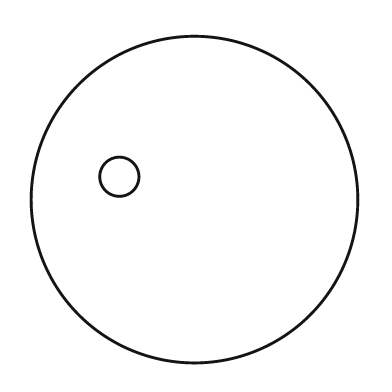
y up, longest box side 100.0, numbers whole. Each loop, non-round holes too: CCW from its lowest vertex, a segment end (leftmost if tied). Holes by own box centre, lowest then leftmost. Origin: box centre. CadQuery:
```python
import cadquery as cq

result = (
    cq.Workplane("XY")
    .moveTo(0.0, 0.0)
    .circle(50.0)
    .moveTo(-23.0, 7.0)
    .circle(6.0)
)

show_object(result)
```